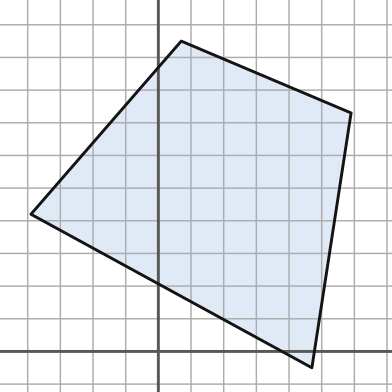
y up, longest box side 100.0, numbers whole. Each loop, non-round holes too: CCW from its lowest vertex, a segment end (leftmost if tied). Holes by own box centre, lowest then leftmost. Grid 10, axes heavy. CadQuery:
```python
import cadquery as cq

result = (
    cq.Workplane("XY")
    .moveTo(47.0, -5.0)
    .lineTo(59.0, 73.0)
    .lineTo(7.0, 95.0)
    .lineTo(-39.0, 42.0)
    .close()
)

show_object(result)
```